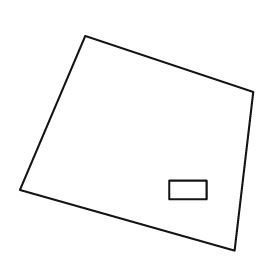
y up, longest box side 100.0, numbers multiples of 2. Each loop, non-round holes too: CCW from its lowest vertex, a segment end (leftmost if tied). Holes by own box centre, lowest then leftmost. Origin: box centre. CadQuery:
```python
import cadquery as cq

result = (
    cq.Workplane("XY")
    .moveTo(42.0, -46.0)
    .lineTo(50.0, 22.0)
    .lineTo(-22.0, 46.0)
    .lineTo(-50.0, -20.0)
    .close()
    .moveTo(14.0, -24.0)
    .lineTo(30.0, -24.0)
    .lineTo(30.0, -16.0)
    .lineTo(14.0, -16.0)
    .close()
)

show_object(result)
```